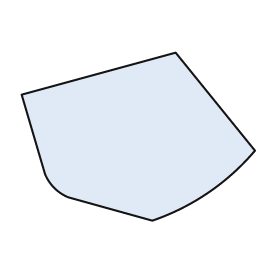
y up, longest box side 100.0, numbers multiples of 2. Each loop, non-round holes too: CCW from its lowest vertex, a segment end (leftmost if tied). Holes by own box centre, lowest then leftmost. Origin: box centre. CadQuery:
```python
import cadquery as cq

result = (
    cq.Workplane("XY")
    .moveTo(6.0, -36.0)
    .threePointArc((30.0, -24.0), (50.0, -6.0))
    .lineTo(16.0, 36.0)
    .lineTo(-50.0, 18.0)
    .lineTo(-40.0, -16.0)
    .threePointArc((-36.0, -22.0), (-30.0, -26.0))
    .close()
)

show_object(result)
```